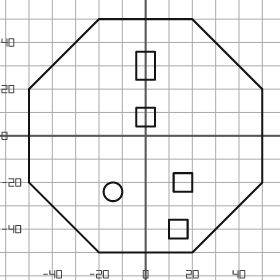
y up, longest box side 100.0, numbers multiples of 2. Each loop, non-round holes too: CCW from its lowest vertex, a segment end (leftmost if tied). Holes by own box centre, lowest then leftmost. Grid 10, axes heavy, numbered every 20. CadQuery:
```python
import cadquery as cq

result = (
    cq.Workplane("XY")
    .moveTo(-20.0, -50.0)
    .lineTo(20.0, -50.0)
    .lineTo(50.0, -20.0)
    .lineTo(50.0, 20.0)
    .lineTo(20.0, 50.0)
    .lineTo(-20.0, 50.0)
    .lineTo(-50.0, 20.0)
    .lineTo(-50.0, -20.0)
    .close()
    .moveTo(10.0, -44.0)
    .lineTo(18.0, -44.0)
    .lineTo(18.0, -36.0)
    .lineTo(10.0, -36.0)
    .close()
    .moveTo(-14.0, -24.0)
    .circle(4.0)
    .moveTo(12.0, -24.0)
    .lineTo(20.0, -24.0)
    .lineTo(20.0, -16.0)
    .lineTo(12.0, -16.0)
    .close()
    .moveTo(-4.0, 4.0)
    .lineTo(4.0, 4.0)
    .lineTo(4.0, 12.0)
    .lineTo(-4.0, 12.0)
    .close()
    .moveTo(-4.0, 24.0)
    .lineTo(4.0, 24.0)
    .lineTo(4.0, 36.0)
    .lineTo(-4.0, 36.0)
    .close()
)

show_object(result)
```